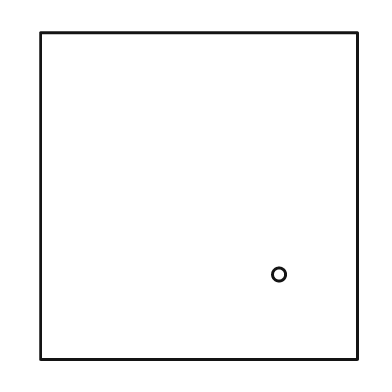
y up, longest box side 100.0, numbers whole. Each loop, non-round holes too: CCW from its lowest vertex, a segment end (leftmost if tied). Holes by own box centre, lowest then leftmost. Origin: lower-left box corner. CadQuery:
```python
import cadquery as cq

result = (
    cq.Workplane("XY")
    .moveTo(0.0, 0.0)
    .lineTo(97.0, 0.0)
    .lineTo(97.0, 100.0)
    .lineTo(0.0, 100.0)
    .close()
    .moveTo(73.0, 26.0)
    .circle(2.0)
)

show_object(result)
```